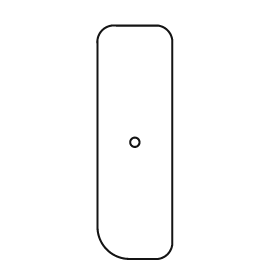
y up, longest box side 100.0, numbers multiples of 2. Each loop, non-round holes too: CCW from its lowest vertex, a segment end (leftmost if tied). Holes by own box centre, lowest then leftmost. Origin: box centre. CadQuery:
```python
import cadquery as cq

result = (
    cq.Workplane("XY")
    .moveTo(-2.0, -50.0)
    .lineTo(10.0, -50.0)
    .threePointArc((14.0, -48.0), (16.0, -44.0))
    .lineTo(16.0, 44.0)
    .threePointArc((14.0, 48.0), (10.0, 50.0))
    .lineTo(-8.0, 50.0)
    .threePointArc((-14.0, 48.0), (-16.0, 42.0))
    .lineTo(-16.0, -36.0)
    .threePointArc((-12.0, -46.0), (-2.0, -50.0))
    .close()
    .moveTo(0.0, 0.0)
    .circle(2.0)
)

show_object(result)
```